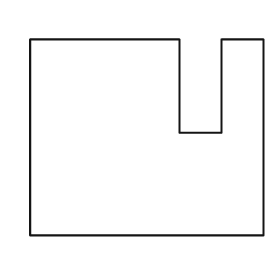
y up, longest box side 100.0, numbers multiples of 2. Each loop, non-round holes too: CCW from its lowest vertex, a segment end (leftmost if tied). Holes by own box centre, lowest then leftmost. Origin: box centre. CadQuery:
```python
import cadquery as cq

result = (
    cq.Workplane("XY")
    .moveTo(-50.0, -42.0)
    .lineTo(50.0, -42.0)
    .lineTo(50.0, 42.0)
    .lineTo(32.0, 42.0)
    .lineTo(32.0, 2.0)
    .lineTo(14.0, 2.0)
    .lineTo(14.0, 42.0)
    .lineTo(-50.0, 42.0)
    .close()
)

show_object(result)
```